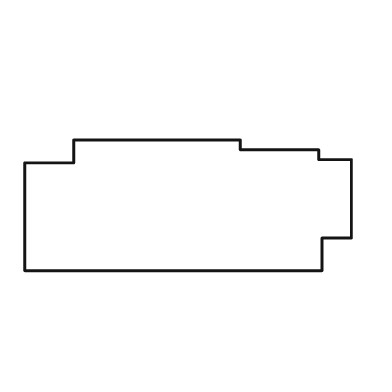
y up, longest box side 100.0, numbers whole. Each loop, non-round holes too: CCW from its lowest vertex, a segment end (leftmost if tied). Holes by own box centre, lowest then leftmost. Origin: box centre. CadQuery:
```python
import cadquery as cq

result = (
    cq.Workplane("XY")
    .moveTo(-50.0, -20.0)
    .lineTo(41.0, -20.0)
    .lineTo(41.0, -10.0)
    .lineTo(50.0, -10.0)
    .lineTo(50.0, 14.0)
    .lineTo(40.0, 14.0)
    .lineTo(40.0, 17.0)
    .lineTo(16.0, 17.0)
    .lineTo(16.0, 20.0)
    .lineTo(-35.0, 20.0)
    .lineTo(-35.0, 13.0)
    .lineTo(-50.0, 13.0)
    .close()
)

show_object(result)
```